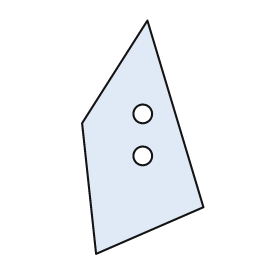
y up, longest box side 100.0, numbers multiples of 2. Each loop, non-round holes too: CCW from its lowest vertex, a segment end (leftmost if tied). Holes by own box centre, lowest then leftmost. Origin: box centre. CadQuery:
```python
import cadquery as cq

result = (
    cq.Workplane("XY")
    .moveTo(-20.0, -50.0)
    .lineTo(26.0, -30.0)
    .lineTo(2.0, 50.0)
    .lineTo(-26.0, 6.0)
    .close()
    .moveTo(0.0, -8.0)
    .circle(4.0)
    .moveTo(0.0, 10.0)
    .circle(4.0)
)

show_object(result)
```